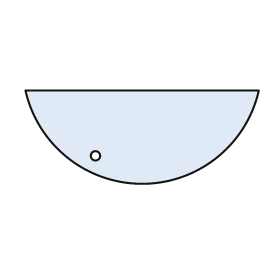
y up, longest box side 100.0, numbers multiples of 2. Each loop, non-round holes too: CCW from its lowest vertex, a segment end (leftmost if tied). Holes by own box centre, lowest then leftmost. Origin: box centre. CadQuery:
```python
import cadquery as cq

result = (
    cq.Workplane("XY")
    .moveTo(-50.0, 20.0)
    .threePointArc((0.0, -20.0), (50.0, 20.0))
    .close()
    .moveTo(-20.0, -8.0)
    .circle(2.0)
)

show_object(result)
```